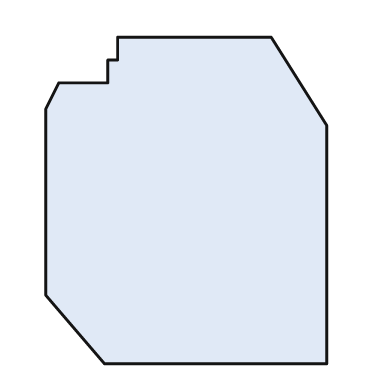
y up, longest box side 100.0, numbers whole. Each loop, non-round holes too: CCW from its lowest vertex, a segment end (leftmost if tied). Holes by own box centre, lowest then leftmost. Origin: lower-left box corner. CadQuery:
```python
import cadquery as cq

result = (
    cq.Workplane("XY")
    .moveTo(18.0, 0.0)
    .lineTo(86.0, 0.0)
    .lineTo(86.0, 73.0)
    .lineTo(69.0, 100.0)
    .lineTo(22.0, 100.0)
    .lineTo(22.0, 93.0)
    .lineTo(19.0, 93.0)
    .lineTo(19.0, 86.0)
    .lineTo(4.0, 86.0)
    .lineTo(0.0, 78.0)
    .lineTo(0.0, 21.0)
    .close()
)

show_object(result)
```